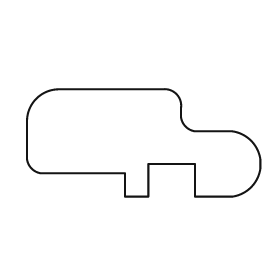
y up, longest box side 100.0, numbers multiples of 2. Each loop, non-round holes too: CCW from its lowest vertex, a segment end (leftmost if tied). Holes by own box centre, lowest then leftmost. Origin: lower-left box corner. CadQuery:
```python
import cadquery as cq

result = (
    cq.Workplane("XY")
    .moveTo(42.0, 0.0)
    .lineTo(52.0, 0.0)
    .lineTo(52.0, 14.0)
    .lineTo(72.0, 14.0)
    .lineTo(72.0, 0.0)
    .lineTo(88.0, 0.0)
    .threePointArc((96.0, 4.0), (100.0, 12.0))
    .lineTo(100.0, 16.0)
    .threePointArc((96.0, 24.0), (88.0, 28.0))
    .lineTo(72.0, 28.0)
    .threePointArc((68.0, 30.0), (66.0, 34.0))
    .lineTo(66.0, 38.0)
    .threePointArc((64.0, 44.0), (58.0, 46.0))
    .lineTo(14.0, 46.0)
    .threePointArc((4.0, 42.0), (0.0, 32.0))
    .lineTo(0.0, 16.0)
    .threePointArc((2.0, 12.0), (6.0, 10.0))
    .lineTo(42.0, 10.0)
    .close()
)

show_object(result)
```